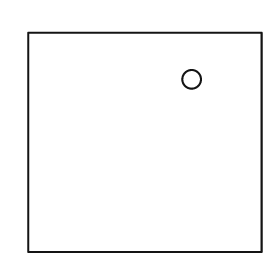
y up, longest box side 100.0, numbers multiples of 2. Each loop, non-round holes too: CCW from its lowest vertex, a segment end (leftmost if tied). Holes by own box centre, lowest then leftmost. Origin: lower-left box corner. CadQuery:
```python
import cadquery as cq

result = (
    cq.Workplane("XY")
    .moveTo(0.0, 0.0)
    .lineTo(100.0, 0.0)
    .lineTo(100.0, 94.0)
    .lineTo(0.0, 94.0)
    .close()
    .moveTo(70.0, 74.0)
    .circle(4.0)
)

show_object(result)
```